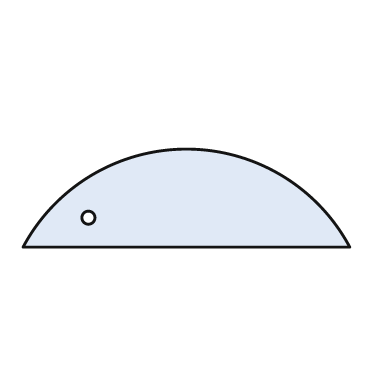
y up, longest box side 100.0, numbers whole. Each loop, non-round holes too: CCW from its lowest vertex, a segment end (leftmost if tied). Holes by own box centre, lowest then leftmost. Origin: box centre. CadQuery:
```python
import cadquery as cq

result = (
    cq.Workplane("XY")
    .moveTo(-50.0, -15.0)
    .lineTo(50.0, -15.0)
    .threePointArc((0.0, 15.0), (-50.0, -15.0))
    .close()
    .moveTo(-30.0, -6.0)
    .circle(2.0)
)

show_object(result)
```